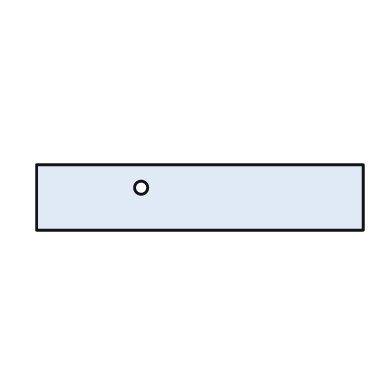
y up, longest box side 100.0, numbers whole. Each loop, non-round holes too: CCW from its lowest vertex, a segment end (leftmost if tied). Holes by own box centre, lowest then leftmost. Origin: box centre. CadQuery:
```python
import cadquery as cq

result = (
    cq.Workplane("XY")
    .moveTo(-50.0, -10.0)
    .lineTo(50.0, -10.0)
    .lineTo(50.0, 10.0)
    .lineTo(-50.0, 10.0)
    .close()
    .moveTo(-18.0, 3.0)
    .circle(2.0)
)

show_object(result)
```